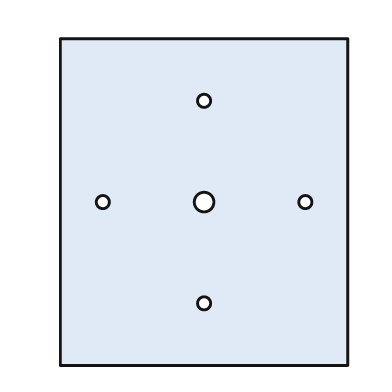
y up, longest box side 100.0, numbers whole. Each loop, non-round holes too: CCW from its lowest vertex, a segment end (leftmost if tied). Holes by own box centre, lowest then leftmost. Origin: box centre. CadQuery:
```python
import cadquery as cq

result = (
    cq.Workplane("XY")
    .moveTo(-44.0, -50.0)
    .lineTo(44.0, -50.0)
    .lineTo(44.0, 50.0)
    .lineTo(-44.0, 50.0)
    .close()
    .moveTo(0.0, -31.0)
    .circle(2.0)
    .moveTo(-31.0, 0.0)
    .circle(2.0)
    .moveTo(0.0, 0.0)
    .circle(3.0)
    .moveTo(31.0, 0.0)
    .circle(2.0)
    .moveTo(0.0, 31.0)
    .circle(2.0)
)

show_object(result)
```